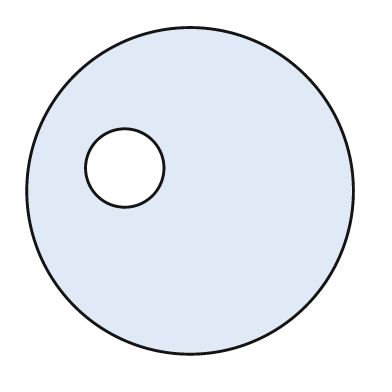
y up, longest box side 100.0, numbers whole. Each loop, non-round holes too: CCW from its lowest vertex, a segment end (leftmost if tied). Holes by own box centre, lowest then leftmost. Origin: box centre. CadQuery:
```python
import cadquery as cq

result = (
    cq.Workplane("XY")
    .moveTo(0.0, 0.0)
    .circle(50.0)
    .moveTo(-20.0, 7.0)
    .circle(12.0)
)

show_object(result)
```